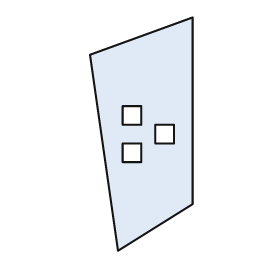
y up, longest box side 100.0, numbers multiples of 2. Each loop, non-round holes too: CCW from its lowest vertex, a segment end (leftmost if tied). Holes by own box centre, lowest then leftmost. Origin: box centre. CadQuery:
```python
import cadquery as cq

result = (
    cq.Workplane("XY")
    .moveTo(-10.0, -50.0)
    .lineTo(22.0, -30.0)
    .lineTo(22.0, 50.0)
    .lineTo(-22.0, 34.0)
    .close()
    .moveTo(-8.0, -12.0)
    .lineTo(0.0, -12.0)
    .lineTo(0.0, -4.0)
    .lineTo(-8.0, -4.0)
    .close()
    .moveTo(6.0, -4.0)
    .lineTo(14.0, -4.0)
    .lineTo(14.0, 4.0)
    .lineTo(6.0, 4.0)
    .close()
    .moveTo(-8.0, 4.0)
    .lineTo(0.0, 4.0)
    .lineTo(0.0, 12.0)
    .lineTo(-8.0, 12.0)
    .close()
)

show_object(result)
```